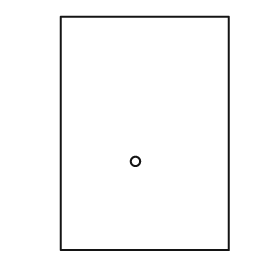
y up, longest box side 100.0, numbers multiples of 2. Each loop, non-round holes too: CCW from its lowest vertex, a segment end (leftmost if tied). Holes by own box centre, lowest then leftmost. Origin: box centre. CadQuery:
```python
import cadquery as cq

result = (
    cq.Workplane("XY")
    .moveTo(-36.0, -50.0)
    .lineTo(36.0, -50.0)
    .lineTo(36.0, 50.0)
    .lineTo(-36.0, 50.0)
    .close()
    .moveTo(-4.0, -12.0)
    .circle(2.0)
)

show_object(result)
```